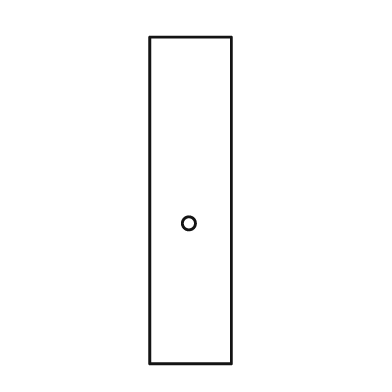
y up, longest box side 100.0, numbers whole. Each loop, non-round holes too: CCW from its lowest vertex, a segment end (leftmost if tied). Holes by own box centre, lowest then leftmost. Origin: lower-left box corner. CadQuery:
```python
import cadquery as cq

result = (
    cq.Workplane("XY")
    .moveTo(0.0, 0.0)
    .lineTo(25.0, 0.0)
    .lineTo(25.0, 100.0)
    .lineTo(0.0, 100.0)
    .close()
    .moveTo(12.0, 43.0)
    .circle(2.0)
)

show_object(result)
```